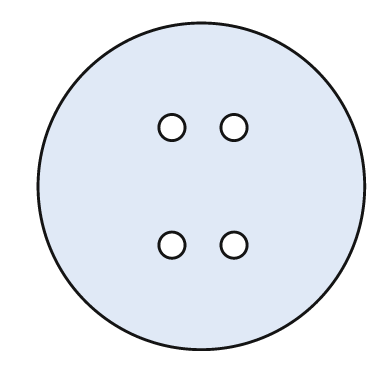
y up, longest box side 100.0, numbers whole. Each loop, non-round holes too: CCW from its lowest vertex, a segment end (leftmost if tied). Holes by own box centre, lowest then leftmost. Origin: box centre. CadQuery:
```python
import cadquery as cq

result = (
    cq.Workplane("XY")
    .moveTo(0.0, 0.0)
    .circle(50.0)
    .moveTo(-9.0, -18.0)
    .circle(4.0)
    .moveTo(10.0, -18.0)
    .circle(4.0)
    .moveTo(-9.0, 18.0)
    .circle(4.0)
    .moveTo(10.0, 18.0)
    .circle(4.0)
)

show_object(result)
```